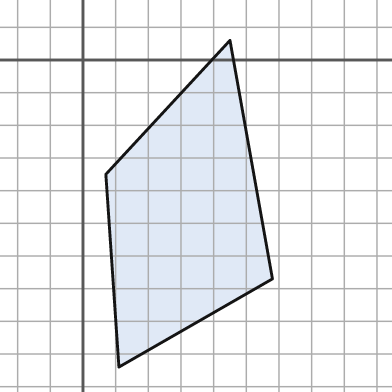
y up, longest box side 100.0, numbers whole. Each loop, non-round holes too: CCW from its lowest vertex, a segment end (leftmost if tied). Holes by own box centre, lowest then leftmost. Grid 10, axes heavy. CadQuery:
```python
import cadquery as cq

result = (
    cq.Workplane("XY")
    .moveTo(11.0, -94.0)
    .lineTo(58.0, -67.0)
    .lineTo(45.0, 6.0)
    .lineTo(7.0, -35.0)
    .close()
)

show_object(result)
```